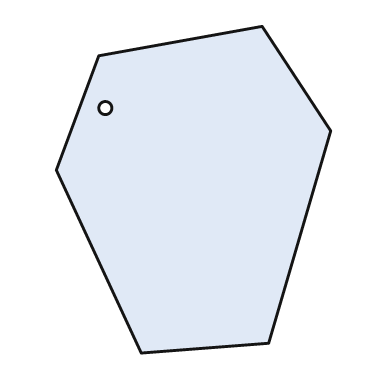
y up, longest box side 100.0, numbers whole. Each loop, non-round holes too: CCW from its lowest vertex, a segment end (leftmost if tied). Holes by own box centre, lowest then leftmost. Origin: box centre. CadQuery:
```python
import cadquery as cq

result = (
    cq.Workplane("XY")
    .moveTo(-16.0, -50.0)
    .lineTo(23.0, -47.0)
    .lineTo(42.0, 18.0)
    .lineTo(21.0, 50.0)
    .lineTo(-29.0, 41.0)
    .lineTo(-42.0, 6.0)
    .close()
    .moveTo(-27.0, 25.0)
    .circle(2.0)
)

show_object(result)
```